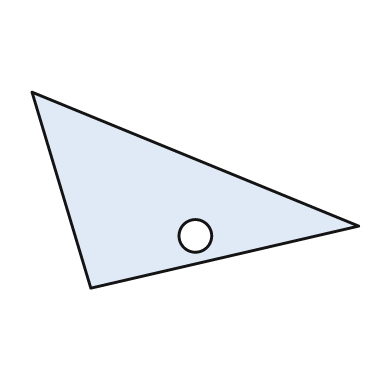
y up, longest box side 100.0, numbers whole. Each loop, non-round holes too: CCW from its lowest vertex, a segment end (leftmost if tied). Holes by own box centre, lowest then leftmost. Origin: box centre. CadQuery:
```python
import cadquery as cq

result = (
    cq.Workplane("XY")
    .moveTo(-32.0, -30.0)
    .lineTo(50.0, -11.0)
    .lineTo(-50.0, 30.0)
    .close()
    .moveTo(0.0, -14.0)
    .circle(5.0)
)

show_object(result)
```